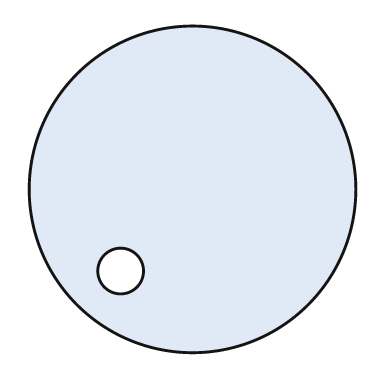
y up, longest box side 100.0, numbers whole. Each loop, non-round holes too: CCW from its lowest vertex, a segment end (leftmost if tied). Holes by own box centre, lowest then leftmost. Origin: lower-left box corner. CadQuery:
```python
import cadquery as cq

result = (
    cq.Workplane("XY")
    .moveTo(50.0, 50.0)
    .circle(50.0)
    .moveTo(28.0, 25.0)
    .circle(7.0)
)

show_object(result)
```